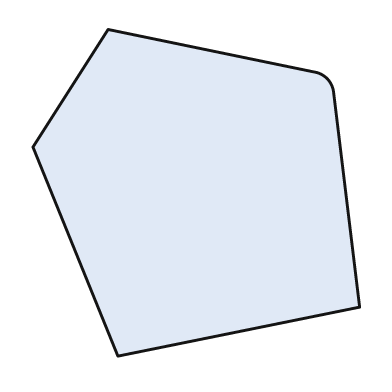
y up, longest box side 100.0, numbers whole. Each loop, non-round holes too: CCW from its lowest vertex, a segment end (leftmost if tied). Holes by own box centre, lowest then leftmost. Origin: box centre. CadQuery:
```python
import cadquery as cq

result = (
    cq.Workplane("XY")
    .moveTo(-24.0, -50.0)
    .lineTo(50.0, -35.0)
    .lineTo(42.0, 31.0)
    .threePointArc((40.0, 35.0), (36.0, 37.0))
    .lineTo(-27.0, 50.0)
    .lineTo(-50.0, 14.0)
    .close()
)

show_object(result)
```